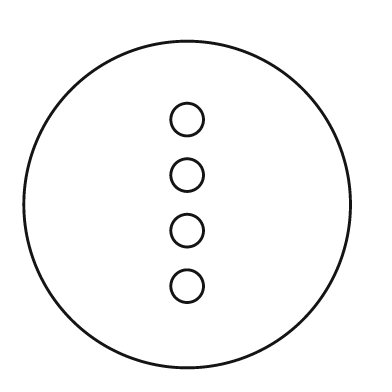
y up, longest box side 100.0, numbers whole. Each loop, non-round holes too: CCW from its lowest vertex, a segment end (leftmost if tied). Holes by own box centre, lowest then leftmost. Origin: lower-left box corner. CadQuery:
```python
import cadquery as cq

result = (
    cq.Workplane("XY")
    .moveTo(50.0, 50.0)
    .circle(50.0)
    .moveTo(50.0, 25.0)
    .circle(5.0)
    .moveTo(50.0, 42.0)
    .circle(5.0)
    .moveTo(50.0, 59.0)
    .circle(5.0)
    .moveTo(50.0, 76.0)
    .circle(5.0)
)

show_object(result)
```